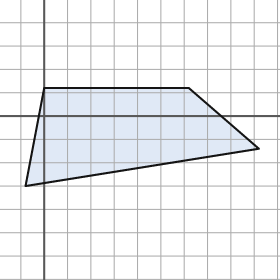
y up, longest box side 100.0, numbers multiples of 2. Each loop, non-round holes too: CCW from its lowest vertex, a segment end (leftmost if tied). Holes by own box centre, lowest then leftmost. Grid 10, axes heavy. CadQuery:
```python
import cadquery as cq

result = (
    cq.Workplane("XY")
    .moveTo(-8.0, -30.0)
    .lineTo(92.0, -14.0)
    .lineTo(62.0, 12.0)
    .lineTo(0.0, 12.0)
    .close()
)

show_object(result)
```